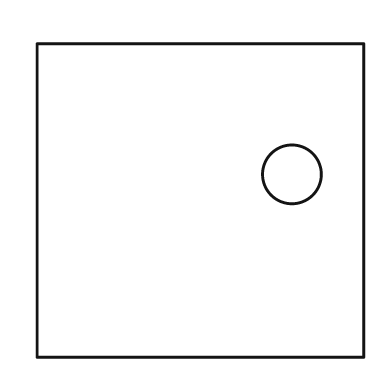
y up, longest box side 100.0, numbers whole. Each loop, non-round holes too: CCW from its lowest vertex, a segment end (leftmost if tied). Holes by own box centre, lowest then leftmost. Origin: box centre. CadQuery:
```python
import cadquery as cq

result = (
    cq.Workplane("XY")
    .moveTo(-50.0, -48.0)
    .lineTo(50.0, -48.0)
    .lineTo(50.0, 48.0)
    .lineTo(-50.0, 48.0)
    .close()
    .moveTo(28.0, 8.0)
    .circle(9.0)
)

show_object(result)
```